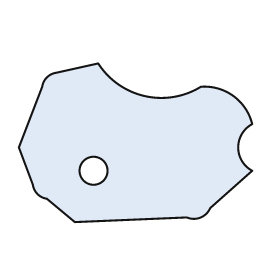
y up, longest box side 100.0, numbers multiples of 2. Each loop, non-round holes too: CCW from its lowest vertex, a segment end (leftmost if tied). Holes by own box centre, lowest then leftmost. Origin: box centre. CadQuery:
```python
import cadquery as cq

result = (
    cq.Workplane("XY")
    .moveTo(-26.0, -34.0)
    .lineTo(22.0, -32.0)
    .threePointArc((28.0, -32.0), (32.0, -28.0))
    .lineTo(50.0, -12.0)
    .threePointArc((44.0, -2.0), (50.0, 8.0))
    .threePointArc((42.0, 20.0), (28.0, 24.0))
    .threePointArc((4.0, 20.0), (-16.0, 34.0))
    .lineTo(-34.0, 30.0)
    .threePointArc((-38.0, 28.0), (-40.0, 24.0))
    .lineTo(-50.0, -2.0)
    .lineTo(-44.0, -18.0)
    .threePointArc((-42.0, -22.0), (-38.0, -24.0))
    .close()
    .moveTo(-18.0, -12.0)
    .circle(6.0)
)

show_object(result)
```